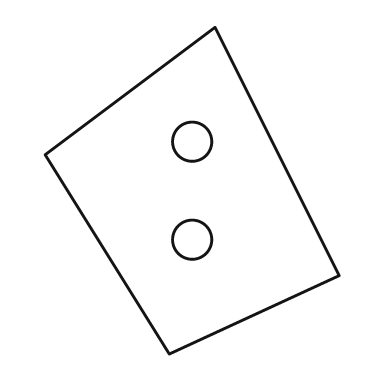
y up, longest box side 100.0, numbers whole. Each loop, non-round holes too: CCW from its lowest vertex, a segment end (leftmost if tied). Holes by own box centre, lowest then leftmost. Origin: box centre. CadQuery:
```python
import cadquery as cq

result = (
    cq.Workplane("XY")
    .moveTo(-7.0, -50.0)
    .lineTo(45.0, -26.0)
    .lineTo(7.0, 50.0)
    .lineTo(-45.0, 11.0)
    .close()
    .moveTo(0.0, -15.0)
    .circle(6.0)
    .moveTo(0.0, 15.0)
    .circle(6.0)
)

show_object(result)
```